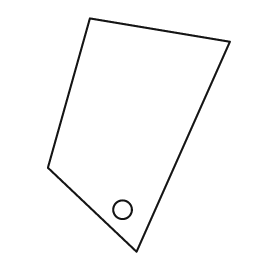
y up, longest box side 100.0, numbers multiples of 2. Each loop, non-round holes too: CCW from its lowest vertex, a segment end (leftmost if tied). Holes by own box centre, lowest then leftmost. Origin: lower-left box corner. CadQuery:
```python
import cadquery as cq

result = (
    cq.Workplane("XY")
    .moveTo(38.0, 0.0)
    .lineTo(78.0, 90.0)
    .lineTo(18.0, 100.0)
    .lineTo(0.0, 36.0)
    .close()
    .moveTo(32.0, 18.0)
    .circle(4.0)
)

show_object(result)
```